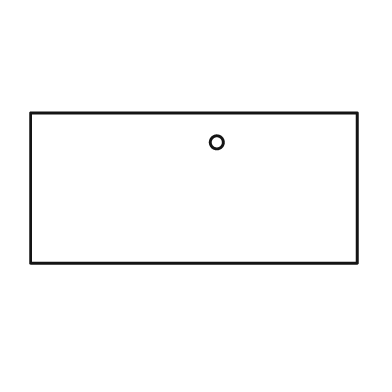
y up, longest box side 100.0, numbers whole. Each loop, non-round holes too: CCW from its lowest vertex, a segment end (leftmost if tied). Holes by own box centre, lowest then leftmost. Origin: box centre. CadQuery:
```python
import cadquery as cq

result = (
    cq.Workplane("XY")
    .moveTo(-50.0, -23.0)
    .lineTo(50.0, -23.0)
    .lineTo(50.0, 23.0)
    .lineTo(-50.0, 23.0)
    .close()
    .moveTo(7.0, 14.0)
    .circle(2.0)
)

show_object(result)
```